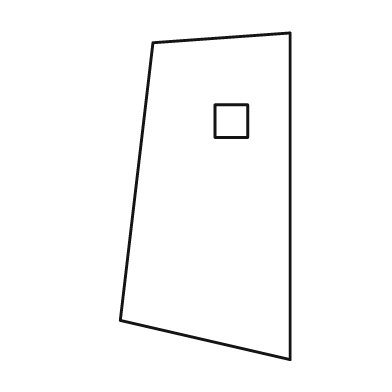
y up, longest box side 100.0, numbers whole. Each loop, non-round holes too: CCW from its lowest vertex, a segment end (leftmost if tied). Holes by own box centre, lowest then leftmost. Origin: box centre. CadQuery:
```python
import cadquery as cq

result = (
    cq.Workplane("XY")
    .moveTo(26.0, -50.0)
    .lineTo(26.0, 50.0)
    .lineTo(-16.0, 47.0)
    .lineTo(-26.0, -38.0)
    .close()
    .moveTo(3.0, 18.0)
    .lineTo(13.0, 18.0)
    .lineTo(13.0, 28.0)
    .lineTo(3.0, 28.0)
    .close()
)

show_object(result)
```